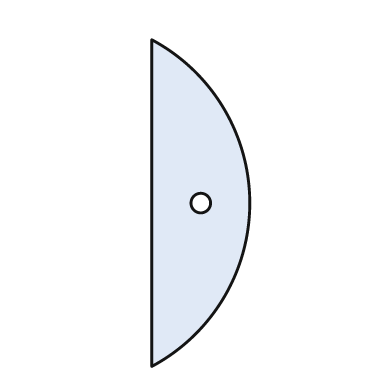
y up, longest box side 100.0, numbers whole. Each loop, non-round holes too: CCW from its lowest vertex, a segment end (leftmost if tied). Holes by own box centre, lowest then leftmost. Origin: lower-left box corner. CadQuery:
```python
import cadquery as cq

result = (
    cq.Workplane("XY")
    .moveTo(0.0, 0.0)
    .threePointArc((30.0, 50.0), (0.0, 100.0))
    .close()
    .moveTo(15.0, 50.0)
    .circle(3.0)
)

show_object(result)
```